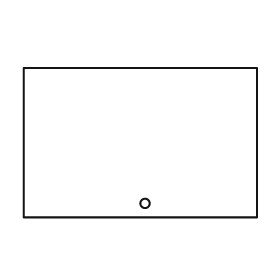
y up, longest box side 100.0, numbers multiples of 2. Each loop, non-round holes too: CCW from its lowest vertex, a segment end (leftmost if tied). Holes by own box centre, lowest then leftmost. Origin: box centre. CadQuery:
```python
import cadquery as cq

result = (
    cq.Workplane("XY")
    .moveTo(-50.0, -32.0)
    .lineTo(50.0, -32.0)
    .lineTo(50.0, 32.0)
    .lineTo(-50.0, 32.0)
    .close()
    .moveTo(2.0, -26.0)
    .circle(2.0)
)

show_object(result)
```